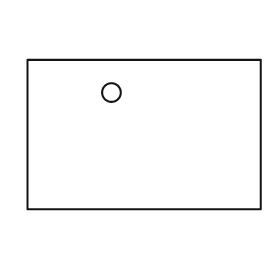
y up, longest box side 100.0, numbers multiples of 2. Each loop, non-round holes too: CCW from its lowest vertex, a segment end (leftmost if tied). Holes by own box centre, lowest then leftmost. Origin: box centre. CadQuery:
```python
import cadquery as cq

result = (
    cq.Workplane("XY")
    .moveTo(-50.0, -32.0)
    .lineTo(50.0, -32.0)
    .lineTo(50.0, 32.0)
    .lineTo(-50.0, 32.0)
    .close()
    .moveTo(-14.0, 18.0)
    .circle(4.0)
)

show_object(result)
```